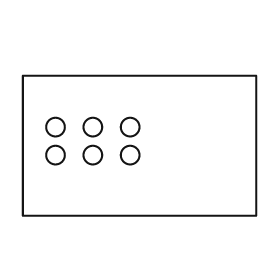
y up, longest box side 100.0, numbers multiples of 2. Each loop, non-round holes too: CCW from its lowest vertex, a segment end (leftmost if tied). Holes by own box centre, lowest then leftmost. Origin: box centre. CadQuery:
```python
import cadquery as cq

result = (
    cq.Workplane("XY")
    .moveTo(-50.0, -30.0)
    .lineTo(50.0, -30.0)
    .lineTo(50.0, 30.0)
    .lineTo(-50.0, 30.0)
    .close()
    .moveTo(-36.0, -4.0)
    .circle(4.0)
    .moveTo(-20.0, -4.0)
    .circle(4.0)
    .moveTo(-4.0, -4.0)
    .circle(4.0)
    .moveTo(-36.0, 8.0)
    .circle(4.0)
    .moveTo(-20.0, 8.0)
    .circle(4.0)
    .moveTo(-4.0, 8.0)
    .circle(4.0)
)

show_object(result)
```